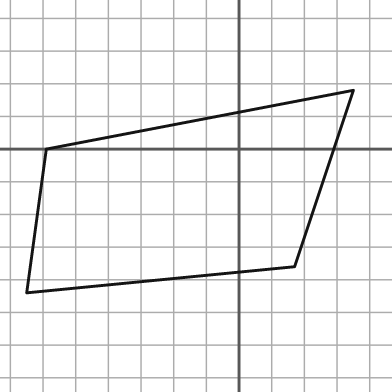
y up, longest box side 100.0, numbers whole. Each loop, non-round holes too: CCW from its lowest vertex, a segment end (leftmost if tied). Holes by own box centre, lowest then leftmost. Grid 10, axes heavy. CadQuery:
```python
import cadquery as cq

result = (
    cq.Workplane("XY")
    .moveTo(-65.0, -44.0)
    .lineTo(17.0, -36.0)
    .lineTo(35.0, 18.0)
    .lineTo(-59.0, 0.0)
    .close()
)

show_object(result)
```